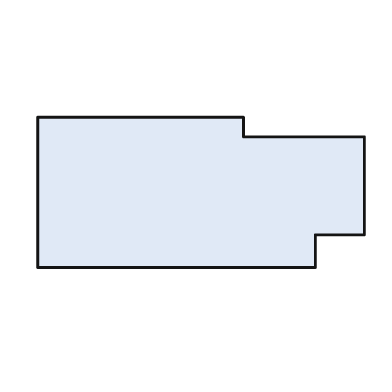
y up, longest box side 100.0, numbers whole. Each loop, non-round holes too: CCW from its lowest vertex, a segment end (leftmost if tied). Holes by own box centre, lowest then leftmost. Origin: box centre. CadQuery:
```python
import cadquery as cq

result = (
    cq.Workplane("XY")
    .moveTo(-50.0, -23.0)
    .lineTo(35.0, -23.0)
    .lineTo(35.0, -13.0)
    .lineTo(50.0, -13.0)
    .lineTo(50.0, 17.0)
    .lineTo(13.0, 17.0)
    .lineTo(13.0, 23.0)
    .lineTo(-50.0, 23.0)
    .close()
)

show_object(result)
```